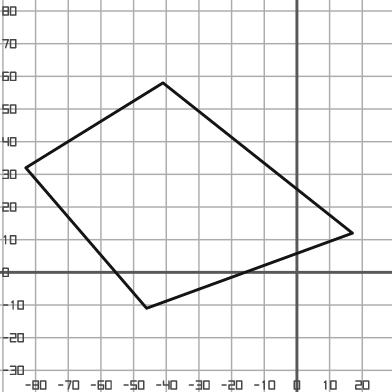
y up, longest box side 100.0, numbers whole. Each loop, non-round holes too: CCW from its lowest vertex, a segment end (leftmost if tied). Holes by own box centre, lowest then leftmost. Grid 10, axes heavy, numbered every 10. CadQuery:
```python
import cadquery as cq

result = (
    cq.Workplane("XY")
    .moveTo(-46.0, -11.0)
    .lineTo(17.0, 12.0)
    .lineTo(-41.0, 58.0)
    .lineTo(-83.0, 32.0)
    .close()
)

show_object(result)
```